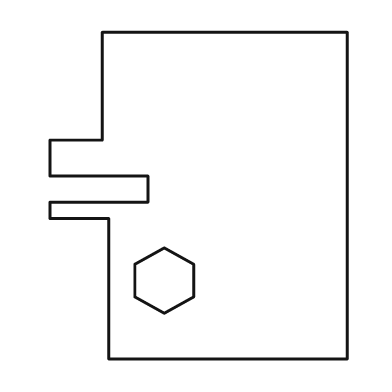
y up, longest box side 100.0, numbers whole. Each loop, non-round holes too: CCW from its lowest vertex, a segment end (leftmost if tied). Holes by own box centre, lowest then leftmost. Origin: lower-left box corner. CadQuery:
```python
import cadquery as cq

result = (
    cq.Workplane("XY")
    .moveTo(18.0, 0.0)
    .lineTo(91.0, 0.0)
    .lineTo(91.0, 100.0)
    .lineTo(16.0, 100.0)
    .lineTo(16.0, 67.0)
    .lineTo(0.0, 67.0)
    .lineTo(0.0, 56.0)
    .lineTo(30.0, 56.0)
    .lineTo(30.0, 48.0)
    .lineTo(0.0, 48.0)
    .lineTo(0.0, 43.0)
    .lineTo(18.0, 43.0)
    .close()
    .moveTo(35.0, 14.0)
    .lineTo(44.0, 19.0)
    .lineTo(44.0, 29.0)
    .lineTo(35.0, 34.0)
    .lineTo(26.0, 29.0)
    .lineTo(26.0, 19.0)
    .close()
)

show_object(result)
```